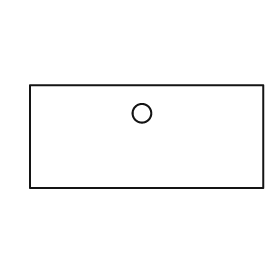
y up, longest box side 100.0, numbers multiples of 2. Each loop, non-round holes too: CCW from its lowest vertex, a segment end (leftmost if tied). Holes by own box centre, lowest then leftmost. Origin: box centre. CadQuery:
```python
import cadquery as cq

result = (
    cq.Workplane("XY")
    .moveTo(-50.0, -22.0)
    .lineTo(50.0, -22.0)
    .lineTo(50.0, 22.0)
    .lineTo(-50.0, 22.0)
    .close()
    .moveTo(-2.0, 10.0)
    .circle(4.0)
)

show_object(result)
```